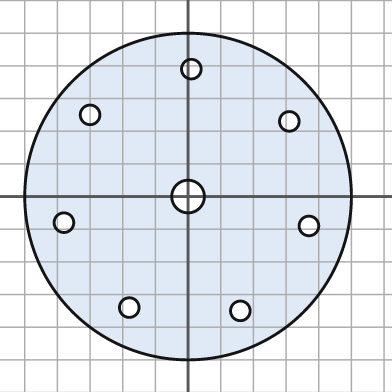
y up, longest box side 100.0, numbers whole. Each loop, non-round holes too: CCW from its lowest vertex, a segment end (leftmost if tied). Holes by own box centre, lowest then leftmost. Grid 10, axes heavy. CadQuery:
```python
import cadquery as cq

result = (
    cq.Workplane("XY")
    .moveTo(0.0, 0.0)
    .circle(50.0)
    .moveTo(16.0, -35.0)
    .circle(3.0)
    .moveTo(-18.0, -34.0)
    .circle(3.0)
    .moveTo(37.0, -9.0)
    .circle(3.0)
    .moveTo(-38.0, -8.0)
    .circle(3.0)
    .moveTo(0.0, 0.0)
    .circle(5.0)
    .moveTo(31.0, 23.0)
    .circle(3.0)
    .moveTo(-30.0, 25.0)
    .circle(3.0)
    .moveTo(1.0, 39.0)
    .circle(3.0)
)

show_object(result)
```